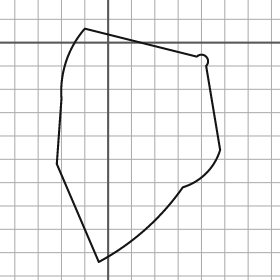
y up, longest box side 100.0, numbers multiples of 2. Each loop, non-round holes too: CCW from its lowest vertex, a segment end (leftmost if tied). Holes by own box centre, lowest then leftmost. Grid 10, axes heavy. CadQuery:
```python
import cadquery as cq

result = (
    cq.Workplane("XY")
    .moveTo(-4.0, -94.0)
    .threePointArc((16.0, -80.0), (32.0, -62.0))
    .threePointArc((42.0, -56.0), (48.0, -46.0))
    .lineTo(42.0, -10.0)
    .threePointArc((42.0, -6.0), (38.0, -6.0))
    .lineTo(-10.0, 6.0)
    .threePointArc((-18.0, -8.0), (-20.0, -24.0))
    .lineTo(-22.0, -52.0)
    .close()
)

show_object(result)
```